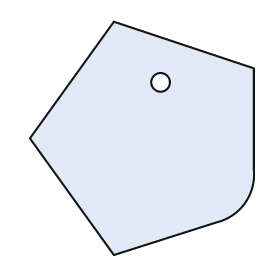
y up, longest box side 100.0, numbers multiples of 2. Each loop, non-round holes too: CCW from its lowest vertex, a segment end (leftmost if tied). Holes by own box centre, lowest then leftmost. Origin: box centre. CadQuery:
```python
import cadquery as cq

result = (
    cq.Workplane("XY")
    .moveTo(-12.0, -50.0)
    .lineTo(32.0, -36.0)
    .threePointArc((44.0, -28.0), (48.0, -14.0))
    .lineTo(48.0, 30.0)
    .lineTo(-12.0, 50.0)
    .lineTo(-48.0, 0.0)
    .close()
    .moveTo(8.0, 24.0)
    .circle(4.0)
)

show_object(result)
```